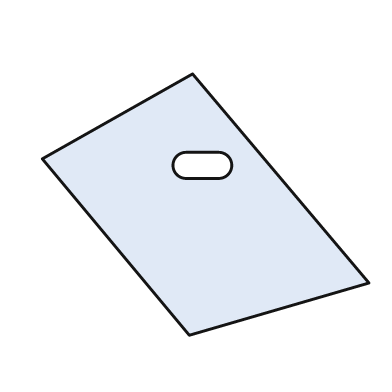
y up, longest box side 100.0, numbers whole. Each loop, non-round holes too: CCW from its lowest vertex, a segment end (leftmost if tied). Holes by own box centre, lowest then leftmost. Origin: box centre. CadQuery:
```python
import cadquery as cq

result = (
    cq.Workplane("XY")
    .moveTo(-5.0, -40.0)
    .lineTo(50.0, -24.0)
    .lineTo(-4.0, 40.0)
    .lineTo(-50.0, 14.0)
    .close()
    .moveTo(-6.0, 8.0)
    .lineTo(4.0, 8.0)
    .threePointArc((8.0, 12.0), (4.0, 16.0))
    .lineTo(-6.0, 16.0)
    .threePointArc((-10.0, 12.0), (-6.0, 8.0))
    .close()
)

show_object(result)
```